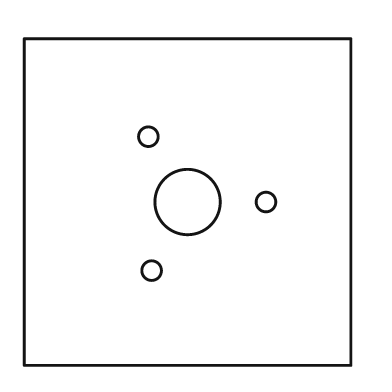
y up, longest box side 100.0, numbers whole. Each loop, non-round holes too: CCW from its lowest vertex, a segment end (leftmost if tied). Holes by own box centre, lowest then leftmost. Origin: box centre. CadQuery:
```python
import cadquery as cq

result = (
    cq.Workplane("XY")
    .moveTo(-50.0, -50.0)
    .lineTo(50.0, -50.0)
    .lineTo(50.0, 50.0)
    .lineTo(-50.0, 50.0)
    .close()
    .moveTo(-11.0, -21.0)
    .circle(3.0)
    .moveTo(0.0, 0.0)
    .circle(10.0)
    .moveTo(24.0, 0.0)
    .circle(3.0)
    .moveTo(-12.0, 20.0)
    .circle(3.0)
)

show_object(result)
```